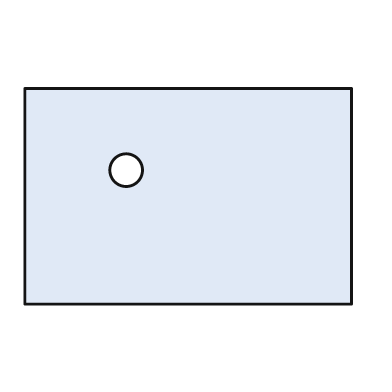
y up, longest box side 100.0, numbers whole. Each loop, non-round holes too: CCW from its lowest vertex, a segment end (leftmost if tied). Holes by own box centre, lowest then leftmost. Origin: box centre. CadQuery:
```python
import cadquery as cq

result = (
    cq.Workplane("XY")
    .moveTo(-50.0, -33.0)
    .lineTo(50.0, -33.0)
    .lineTo(50.0, 33.0)
    .lineTo(-50.0, 33.0)
    .close()
    .moveTo(-19.0, 8.0)
    .circle(5.0)
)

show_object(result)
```